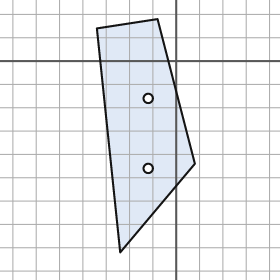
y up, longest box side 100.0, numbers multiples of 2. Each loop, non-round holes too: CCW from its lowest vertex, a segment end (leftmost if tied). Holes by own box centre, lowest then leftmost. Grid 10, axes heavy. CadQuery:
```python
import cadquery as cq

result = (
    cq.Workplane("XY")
    .moveTo(-24.0, -82.0)
    .lineTo(8.0, -44.0)
    .lineTo(-8.0, 18.0)
    .lineTo(-34.0, 14.0)
    .close()
    .moveTo(-12.0, -46.0)
    .circle(2.0)
    .moveTo(-12.0, -16.0)
    .circle(2.0)
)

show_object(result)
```